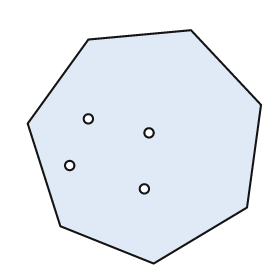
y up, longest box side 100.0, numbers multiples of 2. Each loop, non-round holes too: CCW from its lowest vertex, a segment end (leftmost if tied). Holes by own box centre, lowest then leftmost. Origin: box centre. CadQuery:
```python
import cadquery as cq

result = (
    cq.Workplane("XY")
    .moveTo(4.0, -50.0)
    .lineTo(44.0, -26.0)
    .lineTo(50.0, 18.0)
    .lineTo(20.0, 50.0)
    .lineTo(-24.0, 46.0)
    .lineTo(-50.0, 10.0)
    .lineTo(-36.0, -34.0)
    .close()
    .moveTo(0.0, -18.0)
    .circle(2.0)
    .moveTo(-32.0, -8.0)
    .circle(2.0)
    .moveTo(2.0, 6.0)
    .circle(2.0)
    .moveTo(-24.0, 12.0)
    .circle(2.0)
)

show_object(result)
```